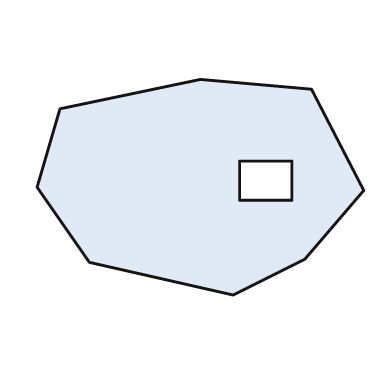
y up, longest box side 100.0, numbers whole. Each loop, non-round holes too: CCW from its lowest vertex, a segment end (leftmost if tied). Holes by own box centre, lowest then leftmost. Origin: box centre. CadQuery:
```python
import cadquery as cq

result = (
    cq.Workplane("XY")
    .moveTo(10.0, -33.0)
    .lineTo(32.0, -22.0)
    .lineTo(50.0, -1.0)
    .lineTo(34.0, 30.0)
    .lineTo(0.0, 33.0)
    .lineTo(-43.0, 24.0)
    .lineTo(-50.0, 0.0)
    .lineTo(-34.0, -23.0)
    .close()
    .moveTo(12.0, -4.0)
    .lineTo(28.0, -4.0)
    .lineTo(28.0, 8.0)
    .lineTo(12.0, 8.0)
    .close()
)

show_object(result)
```